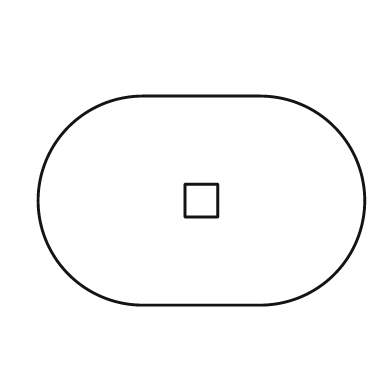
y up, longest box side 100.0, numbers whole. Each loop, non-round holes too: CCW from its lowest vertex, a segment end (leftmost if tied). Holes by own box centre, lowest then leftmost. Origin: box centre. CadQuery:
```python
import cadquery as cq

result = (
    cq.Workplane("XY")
    .moveTo(-18.0, -32.0)
    .lineTo(18.0, -32.0)
    .threePointArc((50.0, 0.0), (18.0, 32.0))
    .lineTo(-18.0, 32.0)
    .threePointArc((-50.0, 0.0), (-18.0, -32.0))
    .close()
    .moveTo(-5.0, -5.0)
    .lineTo(5.0, -5.0)
    .lineTo(5.0, 5.0)
    .lineTo(-5.0, 5.0)
    .close()
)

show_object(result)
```